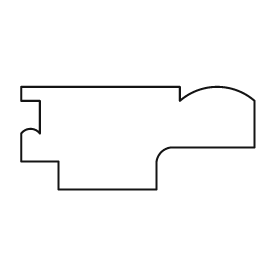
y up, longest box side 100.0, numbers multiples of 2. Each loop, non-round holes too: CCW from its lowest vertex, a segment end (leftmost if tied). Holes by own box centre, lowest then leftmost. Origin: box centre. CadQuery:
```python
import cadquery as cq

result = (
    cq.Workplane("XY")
    .moveTo(-34.0, -22.0)
    .lineTo(8.0, -22.0)
    .lineTo(8.0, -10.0)
    .threePointArc((10.0, -6.0), (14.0, -4.0))
    .lineTo(50.0, -4.0)
    .lineTo(50.0, 16.0)
    .threePointArc((34.0, 22.0), (18.0, 16.0))
    .lineTo(18.0, 22.0)
    .lineTo(-50.0, 22.0)
    .lineTo(-50.0, 16.0)
    .lineTo(-42.0, 16.0)
    .lineTo(-42.0, 2.0)
    .threePointArc((-46.0, 4.0), (-50.0, 2.0))
    .lineTo(-50.0, -10.0)
    .lineTo(-34.0, -10.0)
    .close()
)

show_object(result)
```